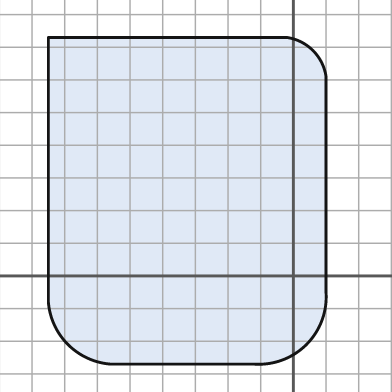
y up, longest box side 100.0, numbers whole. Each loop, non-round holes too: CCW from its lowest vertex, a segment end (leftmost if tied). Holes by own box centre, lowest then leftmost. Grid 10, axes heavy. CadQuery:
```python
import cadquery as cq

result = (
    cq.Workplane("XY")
    .moveTo(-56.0, -27.0)
    .lineTo(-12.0, -27.0)
    .threePointArc((4.0, -21.0), (10.0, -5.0))
    .lineTo(10.0, 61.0)
    .threePointArc((6.0, 69.0), (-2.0, 73.0))
    .lineTo(-75.0, 73.0)
    .lineTo(-75.0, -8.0)
    .threePointArc((-69.0, -21.0), (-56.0, -27.0))
    .close()
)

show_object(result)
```